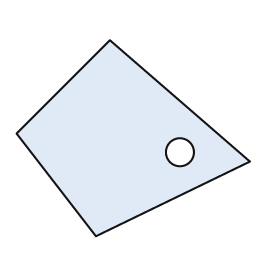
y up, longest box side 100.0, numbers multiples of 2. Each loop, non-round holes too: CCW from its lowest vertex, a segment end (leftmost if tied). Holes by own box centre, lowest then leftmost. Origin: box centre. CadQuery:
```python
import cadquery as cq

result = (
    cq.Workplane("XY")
    .moveTo(-16.0, -42.0)
    .lineTo(50.0, -10.0)
    .lineTo(-10.0, 42.0)
    .lineTo(-50.0, 2.0)
    .close()
    .moveTo(20.0, -6.0)
    .circle(6.0)
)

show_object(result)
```